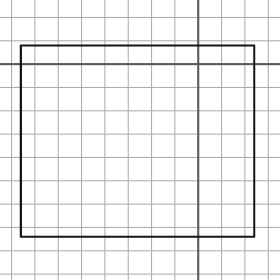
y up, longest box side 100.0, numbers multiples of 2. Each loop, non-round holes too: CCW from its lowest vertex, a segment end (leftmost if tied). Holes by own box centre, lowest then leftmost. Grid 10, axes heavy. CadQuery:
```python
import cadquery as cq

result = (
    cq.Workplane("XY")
    .moveTo(-76.0, -74.0)
    .lineTo(24.0, -74.0)
    .lineTo(24.0, 8.0)
    .lineTo(-76.0, 8.0)
    .close()
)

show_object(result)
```